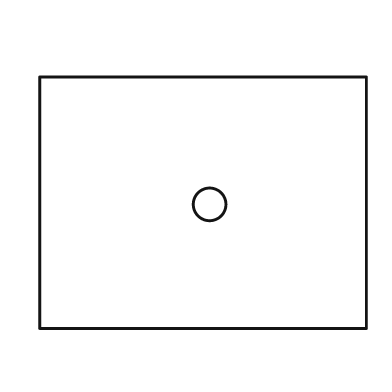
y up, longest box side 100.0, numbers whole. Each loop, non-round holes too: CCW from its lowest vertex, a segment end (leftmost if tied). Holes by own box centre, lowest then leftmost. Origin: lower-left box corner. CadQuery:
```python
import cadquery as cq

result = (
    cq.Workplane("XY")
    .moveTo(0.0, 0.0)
    .lineTo(100.0, 0.0)
    .lineTo(100.0, 77.0)
    .lineTo(0.0, 77.0)
    .close()
    .moveTo(52.0, 38.0)
    .circle(5.0)
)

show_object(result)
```